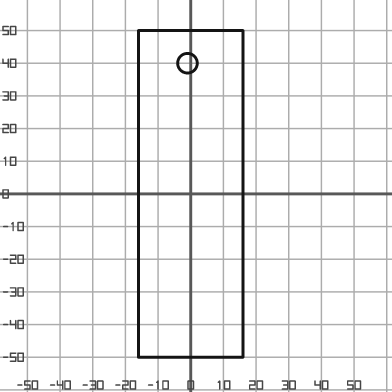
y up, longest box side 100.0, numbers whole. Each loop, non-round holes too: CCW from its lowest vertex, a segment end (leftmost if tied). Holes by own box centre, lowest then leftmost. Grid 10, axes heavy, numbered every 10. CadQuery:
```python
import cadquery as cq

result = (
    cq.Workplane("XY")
    .moveTo(-16.0, -50.0)
    .lineTo(16.0, -50.0)
    .lineTo(16.0, 50.0)
    .lineTo(-16.0, 50.0)
    .close()
    .moveTo(-1.0, 40.0)
    .circle(3.0)
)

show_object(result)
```